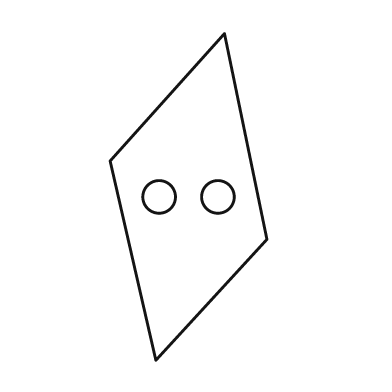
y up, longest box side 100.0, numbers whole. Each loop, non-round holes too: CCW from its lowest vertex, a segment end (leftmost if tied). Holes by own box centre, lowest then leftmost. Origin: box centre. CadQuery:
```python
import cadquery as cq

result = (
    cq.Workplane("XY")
    .moveTo(-10.0, -50.0)
    .lineTo(24.0, -13.0)
    .lineTo(11.0, 50.0)
    .lineTo(-24.0, 11.0)
    .close()
    .moveTo(-9.0, 0.0)
    .circle(5.0)
    .moveTo(9.0, 0.0)
    .circle(5.0)
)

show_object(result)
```